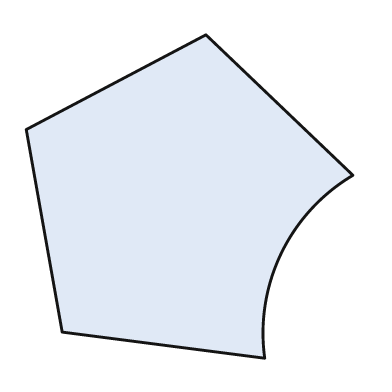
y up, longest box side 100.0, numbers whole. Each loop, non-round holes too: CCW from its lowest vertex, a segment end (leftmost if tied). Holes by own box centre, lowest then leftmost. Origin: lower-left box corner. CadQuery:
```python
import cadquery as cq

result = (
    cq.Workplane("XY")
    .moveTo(73.0, 0.0)
    .threePointArc((78.0, 32.0), (100.0, 56.0))
    .lineTo(55.0, 99.0)
    .lineTo(0.0, 70.0)
    .lineTo(11.0, 8.0)
    .close()
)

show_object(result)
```